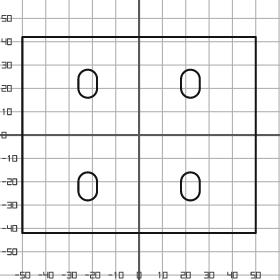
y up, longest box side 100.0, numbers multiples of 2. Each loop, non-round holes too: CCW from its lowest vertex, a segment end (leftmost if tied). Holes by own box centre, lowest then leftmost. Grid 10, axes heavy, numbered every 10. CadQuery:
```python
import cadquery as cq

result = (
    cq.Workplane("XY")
    .moveTo(-50.0, -42.0)
    .lineTo(50.0, -42.0)
    .lineTo(50.0, 42.0)
    .lineTo(-50.0, 42.0)
    .close()
    .moveTo(-26.0, -24.0)
    .threePointArc((-22.0, -28.0), (-18.0, -24.0))
    .lineTo(-18.0, -20.0)
    .threePointArc((-22.0, -16.0), (-26.0, -20.0))
    .close()
    .moveTo(18.0, -24.0)
    .threePointArc((22.0, -28.0), (26.0, -24.0))
    .lineTo(26.0, -20.0)
    .threePointArc((22.0, -16.0), (18.0, -20.0))
    .close()
    .moveTo(-26.0, 20.0)
    .threePointArc((-22.0, 16.0), (-18.0, 20.0))
    .lineTo(-18.0, 24.0)
    .threePointArc((-22.0, 28.0), (-26.0, 24.0))
    .close()
    .moveTo(18.0, 20.0)
    .threePointArc((22.0, 16.0), (26.0, 20.0))
    .lineTo(26.0, 24.0)
    .threePointArc((22.0, 28.0), (18.0, 24.0))
    .close()
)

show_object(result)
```